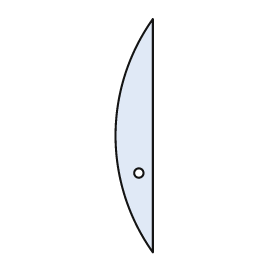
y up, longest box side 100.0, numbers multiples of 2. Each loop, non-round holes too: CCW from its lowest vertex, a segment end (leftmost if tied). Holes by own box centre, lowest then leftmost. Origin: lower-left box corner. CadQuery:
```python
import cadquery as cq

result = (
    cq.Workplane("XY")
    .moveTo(16.0, 0.0)
    .lineTo(16.0, 100.0)
    .threePointArc((0.0, 50.0), (16.0, 0.0))
    .close()
    .moveTo(10.0, 34.0)
    .circle(2.0)
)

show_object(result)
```